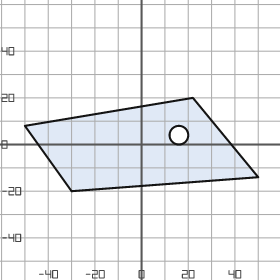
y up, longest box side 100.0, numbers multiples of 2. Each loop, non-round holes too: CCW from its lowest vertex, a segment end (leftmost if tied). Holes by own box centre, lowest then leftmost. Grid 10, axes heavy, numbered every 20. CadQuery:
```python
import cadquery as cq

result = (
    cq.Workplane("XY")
    .moveTo(-30.0, -20.0)
    .lineTo(50.0, -14.0)
    .lineTo(22.0, 20.0)
    .lineTo(-50.0, 8.0)
    .close()
    .moveTo(16.0, 4.0)
    .circle(4.0)
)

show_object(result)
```